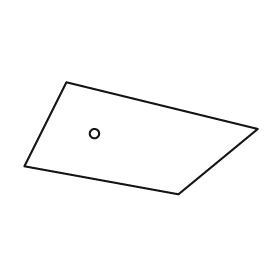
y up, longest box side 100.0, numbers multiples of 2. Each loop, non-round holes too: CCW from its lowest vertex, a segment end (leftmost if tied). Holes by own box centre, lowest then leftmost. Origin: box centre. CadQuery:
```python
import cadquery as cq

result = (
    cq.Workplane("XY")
    .moveTo(16.0, -24.0)
    .lineTo(50.0, 4.0)
    .lineTo(-32.0, 24.0)
    .lineTo(-50.0, -12.0)
    .close()
    .moveTo(-20.0, 2.0)
    .circle(2.0)
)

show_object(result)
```